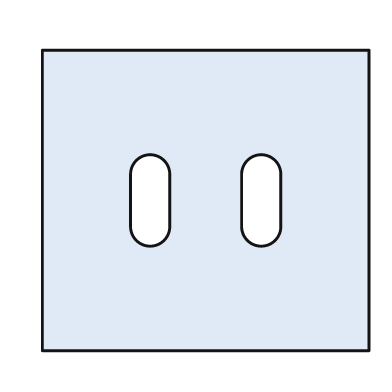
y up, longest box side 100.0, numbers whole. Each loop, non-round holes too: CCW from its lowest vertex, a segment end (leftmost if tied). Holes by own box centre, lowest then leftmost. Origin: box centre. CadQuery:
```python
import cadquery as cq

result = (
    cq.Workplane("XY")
    .moveTo(-50.0, -46.0)
    .lineTo(50.0, -46.0)
    .lineTo(50.0, 46.0)
    .lineTo(-50.0, 46.0)
    .close()
    .moveTo(-23.0, -8.0)
    .threePointArc((-17.0, -14.0), (-11.0, -8.0))
    .lineTo(-11.0, 8.0)
    .threePointArc((-17.0, 14.0), (-23.0, 8.0))
    .close()
    .moveTo(11.0, -8.0)
    .threePointArc((17.0, -14.0), (23.0, -8.0))
    .lineTo(23.0, 8.0)
    .threePointArc((17.0, 14.0), (11.0, 8.0))
    .close()
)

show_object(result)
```